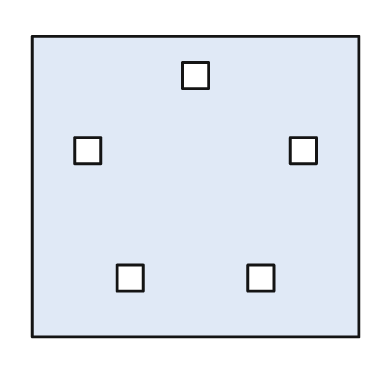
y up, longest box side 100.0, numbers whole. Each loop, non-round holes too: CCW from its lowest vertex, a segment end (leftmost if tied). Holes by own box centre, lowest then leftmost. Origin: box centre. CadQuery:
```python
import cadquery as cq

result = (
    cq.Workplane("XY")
    .moveTo(-50.0, -46.0)
    .lineTo(50.0, -46.0)
    .lineTo(50.0, 46.0)
    .lineTo(-50.0, 46.0)
    .close()
    .moveTo(-24.0, -32.0)
    .lineTo(-16.0, -32.0)
    .lineTo(-16.0, -24.0)
    .lineTo(-24.0, -24.0)
    .close()
    .moveTo(16.0, -32.0)
    .lineTo(24.0, -32.0)
    .lineTo(24.0, -24.0)
    .lineTo(16.0, -24.0)
    .close()
    .moveTo(-37.0, 7.0)
    .lineTo(-29.0, 7.0)
    .lineTo(-29.0, 15.0)
    .lineTo(-37.0, 15.0)
    .close()
    .moveTo(29.0, 7.0)
    .lineTo(37.0, 7.0)
    .lineTo(37.0, 15.0)
    .lineTo(29.0, 15.0)
    .close()
    .moveTo(-4.0, 30.0)
    .lineTo(4.0, 30.0)
    .lineTo(4.0, 38.0)
    .lineTo(-4.0, 38.0)
    .close()
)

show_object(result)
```